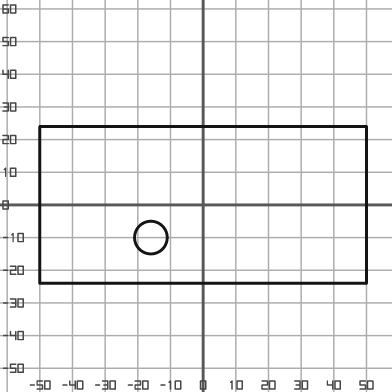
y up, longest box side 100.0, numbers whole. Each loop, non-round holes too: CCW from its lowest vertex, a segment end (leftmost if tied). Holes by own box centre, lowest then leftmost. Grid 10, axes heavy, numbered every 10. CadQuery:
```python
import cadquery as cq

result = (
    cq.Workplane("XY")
    .moveTo(-50.0, -24.0)
    .lineTo(50.0, -24.0)
    .lineTo(50.0, 24.0)
    .lineTo(-50.0, 24.0)
    .close()
    .moveTo(-16.0, -10.0)
    .circle(5.0)
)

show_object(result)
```